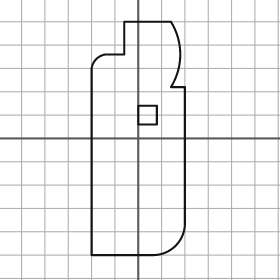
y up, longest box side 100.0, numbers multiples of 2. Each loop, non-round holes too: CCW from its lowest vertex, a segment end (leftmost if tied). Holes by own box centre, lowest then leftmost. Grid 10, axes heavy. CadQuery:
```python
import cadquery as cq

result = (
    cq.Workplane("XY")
    .moveTo(-20.0, -50.0)
    .lineTo(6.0, -50.0)
    .threePointArc((16.0, -46.0), (20.0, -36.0))
    .lineTo(20.0, 22.0)
    .lineTo(14.0, 22.0)
    .threePointArc((18.0, 36.0), (14.0, 50.0))
    .lineTo(-6.0, 50.0)
    .lineTo(-6.0, 36.0)
    .lineTo(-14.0, 36.0)
    .threePointArc((-18.0, 34.0), (-20.0, 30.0))
    .close()
    .moveTo(0.0, 6.0)
    .lineTo(8.0, 6.0)
    .lineTo(8.0, 14.0)
    .lineTo(0.0, 14.0)
    .close()
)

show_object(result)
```